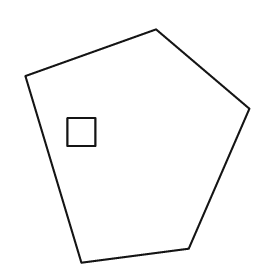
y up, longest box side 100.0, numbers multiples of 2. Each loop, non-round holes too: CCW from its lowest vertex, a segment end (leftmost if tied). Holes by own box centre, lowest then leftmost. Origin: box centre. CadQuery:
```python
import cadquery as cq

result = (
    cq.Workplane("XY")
    .moveTo(-24.0, -50.0)
    .lineTo(22.0, -44.0)
    .lineTo(48.0, 16.0)
    .lineTo(8.0, 50.0)
    .lineTo(-48.0, 30.0)
    .close()
    .moveTo(-30.0, 0.0)
    .lineTo(-18.0, 0.0)
    .lineTo(-18.0, 12.0)
    .lineTo(-30.0, 12.0)
    .close()
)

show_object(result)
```